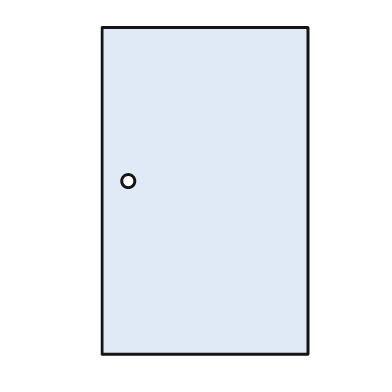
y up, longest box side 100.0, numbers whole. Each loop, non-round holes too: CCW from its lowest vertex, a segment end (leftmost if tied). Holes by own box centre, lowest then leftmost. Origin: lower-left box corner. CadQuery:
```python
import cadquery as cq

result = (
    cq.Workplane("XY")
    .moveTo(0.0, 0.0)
    .lineTo(63.0, 0.0)
    .lineTo(63.0, 100.0)
    .lineTo(0.0, 100.0)
    .close()
    .moveTo(8.0, 53.0)
    .circle(2.0)
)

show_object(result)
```